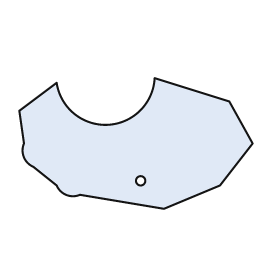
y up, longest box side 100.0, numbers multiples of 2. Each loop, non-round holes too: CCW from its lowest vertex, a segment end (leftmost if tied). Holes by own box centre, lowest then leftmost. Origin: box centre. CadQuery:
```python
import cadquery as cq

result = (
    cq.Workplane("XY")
    .moveTo(12.0, -28.0)
    .lineTo(36.0, -18.0)
    .lineTo(50.0, 0.0)
    .lineTo(40.0, 18.0)
    .lineTo(8.0, 28.0)
    .threePointArc((-12.0, 8.0), (-34.0, 26.0))
    .lineTo(-50.0, 14.0)
    .lineTo(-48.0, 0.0)
    .threePointArc((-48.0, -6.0), (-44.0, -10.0))
    .lineTo(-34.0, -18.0)
    .threePointArc((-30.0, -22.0), (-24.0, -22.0))
    .close()
    .moveTo(2.0, -16.0)
    .circle(2.0)
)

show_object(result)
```